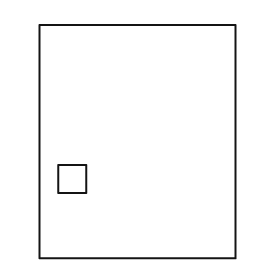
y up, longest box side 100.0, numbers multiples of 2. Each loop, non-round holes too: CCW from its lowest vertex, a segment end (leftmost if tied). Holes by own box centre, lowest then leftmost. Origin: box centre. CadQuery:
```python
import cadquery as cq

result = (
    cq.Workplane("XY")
    .moveTo(-42.0, -50.0)
    .lineTo(42.0, -50.0)
    .lineTo(42.0, 50.0)
    .lineTo(-42.0, 50.0)
    .close()
    .moveTo(-34.0, -22.0)
    .lineTo(-22.0, -22.0)
    .lineTo(-22.0, -10.0)
    .lineTo(-34.0, -10.0)
    .close()
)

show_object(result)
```